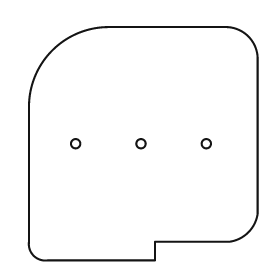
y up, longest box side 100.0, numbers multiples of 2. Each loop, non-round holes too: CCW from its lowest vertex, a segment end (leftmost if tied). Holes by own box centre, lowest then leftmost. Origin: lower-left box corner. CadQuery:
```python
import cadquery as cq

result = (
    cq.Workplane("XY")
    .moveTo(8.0, 0.0)
    .lineTo(54.0, 0.0)
    .lineTo(54.0, 8.0)
    .lineTo(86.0, 8.0)
    .threePointArc((94.0, 12.0), (98.0, 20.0))
    .lineTo(98.0, 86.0)
    .threePointArc((94.0, 96.0), (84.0, 100.0))
    .lineTo(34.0, 100.0)
    .threePointArc((10.0, 90.0), (0.0, 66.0))
    .lineTo(0.0, 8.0)
    .threePointArc((2.0, 2.0), (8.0, 0.0))
    .close()
    .moveTo(20.0, 50.0)
    .circle(2.0)
    .moveTo(48.0, 50.0)
    .circle(2.0)
    .moveTo(76.0, 50.0)
    .circle(2.0)
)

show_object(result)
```